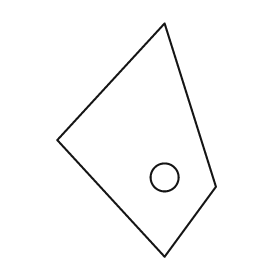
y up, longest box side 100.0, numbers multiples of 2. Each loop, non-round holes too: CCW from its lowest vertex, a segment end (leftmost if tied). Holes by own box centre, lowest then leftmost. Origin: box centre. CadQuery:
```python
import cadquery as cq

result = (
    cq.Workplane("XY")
    .moveTo(12.0, -50.0)
    .lineTo(34.0, -20.0)
    .lineTo(12.0, 50.0)
    .lineTo(-34.0, 0.0)
    .close()
    .moveTo(12.0, -16.0)
    .circle(6.0)
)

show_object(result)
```